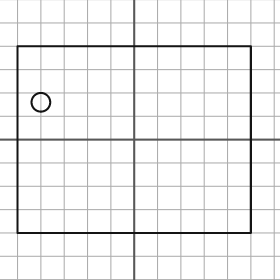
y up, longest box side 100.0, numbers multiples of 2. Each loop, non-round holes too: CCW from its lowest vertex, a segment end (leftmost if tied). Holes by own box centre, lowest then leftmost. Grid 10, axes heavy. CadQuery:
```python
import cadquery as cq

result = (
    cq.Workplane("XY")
    .moveTo(-50.0, -40.0)
    .lineTo(50.0, -40.0)
    .lineTo(50.0, 40.0)
    .lineTo(-50.0, 40.0)
    .close()
    .moveTo(-40.0, 16.0)
    .circle(4.0)
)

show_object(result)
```